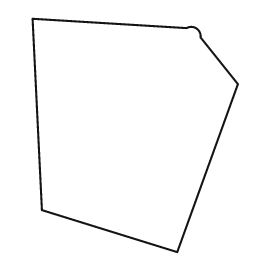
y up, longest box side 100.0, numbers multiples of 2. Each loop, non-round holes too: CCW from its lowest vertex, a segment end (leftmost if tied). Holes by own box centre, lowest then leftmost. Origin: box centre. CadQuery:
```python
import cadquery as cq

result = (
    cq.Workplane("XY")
    .moveTo(18.0, -50.0)
    .lineTo(44.0, 22.0)
    .lineTo(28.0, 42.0)
    .threePointArc((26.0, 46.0), (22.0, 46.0))
    .lineTo(-44.0, 50.0)
    .lineTo(-40.0, -32.0)
    .close()
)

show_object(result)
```